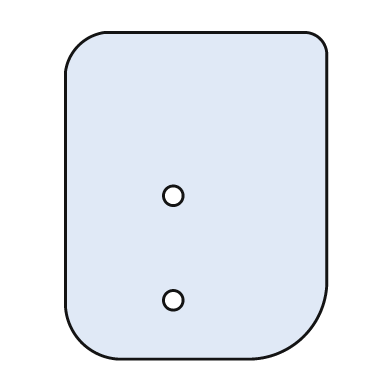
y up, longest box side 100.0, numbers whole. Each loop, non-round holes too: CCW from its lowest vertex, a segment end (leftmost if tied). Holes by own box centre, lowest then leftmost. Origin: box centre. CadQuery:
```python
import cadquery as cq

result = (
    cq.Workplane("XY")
    .moveTo(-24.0, -50.0)
    .lineTo(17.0, -50.0)
    .threePointArc((33.0, -43.0), (40.0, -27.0))
    .lineTo(40.0, 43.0)
    .threePointArc((38.0, 48.0), (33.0, 50.0))
    .lineTo(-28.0, 50.0)
    .threePointArc((-36.0, 46.0), (-40.0, 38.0))
    .lineTo(-40.0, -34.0)
    .threePointArc((-35.0, -45.0), (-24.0, -50.0))
    .close()
    .moveTo(-7.0, -32.0)
    .circle(3.0)
    .moveTo(-7.0, 0.0)
    .circle(3.0)
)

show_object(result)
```